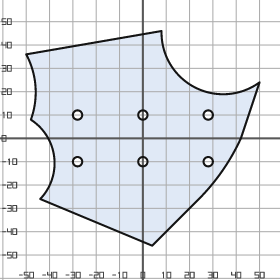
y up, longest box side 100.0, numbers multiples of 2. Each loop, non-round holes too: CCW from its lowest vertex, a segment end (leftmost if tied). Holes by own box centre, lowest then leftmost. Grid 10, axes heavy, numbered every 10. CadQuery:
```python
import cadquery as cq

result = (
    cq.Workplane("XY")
    .moveTo(4.0, -46.0)
    .lineTo(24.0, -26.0)
    .threePointArc((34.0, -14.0), (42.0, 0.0))
    .lineTo(50.0, 24.0)
    .threePointArc((22.0, 22.0), (8.0, 46.0))
    .lineTo(-50.0, 36.0)
    .threePointArc((-46.0, 22.0), (-48.0, 8.0))
    .threePointArc((-38.0, -8.0), (-44.0, -26.0))
    .close()
    .moveTo(-28.0, -10.0)
    .circle(2.0)
    .moveTo(0.0, -10.0)
    .circle(2.0)
    .moveTo(28.0, -10.0)
    .circle(2.0)
    .moveTo(-28.0, 10.0)
    .circle(2.0)
    .moveTo(0.0, 10.0)
    .circle(2.0)
    .moveTo(28.0, 10.0)
    .circle(2.0)
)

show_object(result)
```